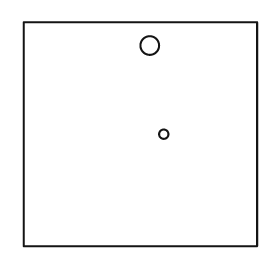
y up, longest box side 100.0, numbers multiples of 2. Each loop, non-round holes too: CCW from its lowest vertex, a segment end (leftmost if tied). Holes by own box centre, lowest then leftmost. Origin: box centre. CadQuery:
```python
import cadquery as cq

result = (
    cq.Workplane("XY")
    .moveTo(-50.0, -48.0)
    .lineTo(50.0, -48.0)
    .lineTo(50.0, 48.0)
    .lineTo(-50.0, 48.0)
    .close()
    .moveTo(10.0, 0.0)
    .circle(2.0)
    .moveTo(4.0, 38.0)
    .circle(4.0)
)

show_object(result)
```